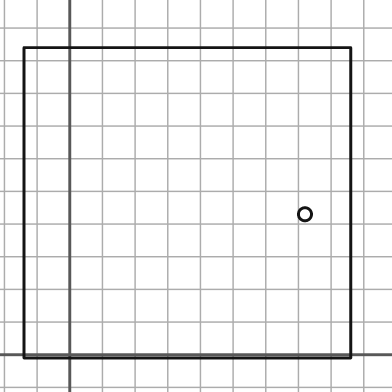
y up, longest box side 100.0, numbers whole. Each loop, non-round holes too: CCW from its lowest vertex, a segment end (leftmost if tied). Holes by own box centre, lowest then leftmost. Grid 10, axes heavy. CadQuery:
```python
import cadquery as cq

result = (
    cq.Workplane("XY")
    .moveTo(-14.0, -1.0)
    .lineTo(86.0, -1.0)
    .lineTo(86.0, 94.0)
    .lineTo(-14.0, 94.0)
    .close()
    .moveTo(72.0, 43.0)
    .circle(2.0)
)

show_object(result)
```